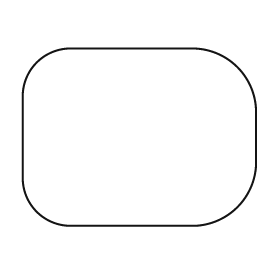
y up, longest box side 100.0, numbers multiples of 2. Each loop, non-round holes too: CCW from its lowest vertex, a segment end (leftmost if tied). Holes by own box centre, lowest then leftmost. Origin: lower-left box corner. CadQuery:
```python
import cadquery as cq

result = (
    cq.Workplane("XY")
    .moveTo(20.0, 0.0)
    .lineTo(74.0, 0.0)
    .threePointArc((92.0, 8.0), (100.0, 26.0))
    .lineTo(100.0, 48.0)
    .threePointArc((92.0, 68.0), (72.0, 76.0))
    .lineTo(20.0, 76.0)
    .threePointArc((6.0, 70.0), (0.0, 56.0))
    .lineTo(0.0, 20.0)
    .threePointArc((6.0, 6.0), (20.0, 0.0))
    .close()
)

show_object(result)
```